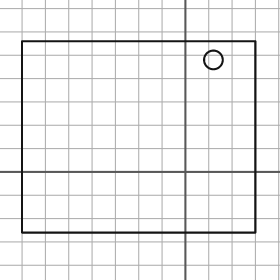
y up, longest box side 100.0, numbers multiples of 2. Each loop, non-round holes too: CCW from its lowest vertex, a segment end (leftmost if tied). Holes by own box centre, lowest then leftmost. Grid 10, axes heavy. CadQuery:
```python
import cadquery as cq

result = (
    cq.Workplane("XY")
    .moveTo(-70.0, -26.0)
    .lineTo(30.0, -26.0)
    .lineTo(30.0, 56.0)
    .lineTo(-70.0, 56.0)
    .close()
    .moveTo(12.0, 48.0)
    .circle(4.0)
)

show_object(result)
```